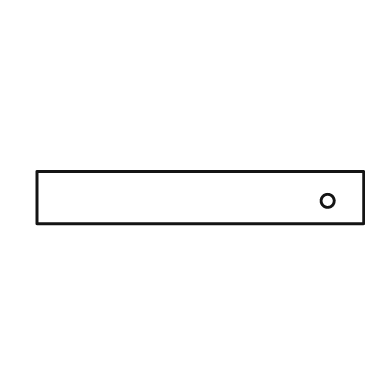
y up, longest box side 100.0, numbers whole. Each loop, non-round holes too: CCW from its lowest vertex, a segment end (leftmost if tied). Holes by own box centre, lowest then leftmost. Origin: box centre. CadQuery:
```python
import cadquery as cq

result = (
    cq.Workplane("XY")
    .moveTo(-50.0, -8.0)
    .lineTo(50.0, -8.0)
    .lineTo(50.0, 8.0)
    .lineTo(-50.0, 8.0)
    .close()
    .moveTo(39.0, -1.0)
    .circle(2.0)
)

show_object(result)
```